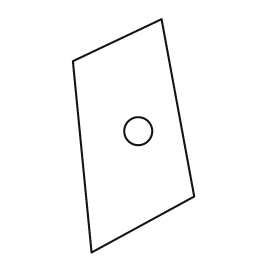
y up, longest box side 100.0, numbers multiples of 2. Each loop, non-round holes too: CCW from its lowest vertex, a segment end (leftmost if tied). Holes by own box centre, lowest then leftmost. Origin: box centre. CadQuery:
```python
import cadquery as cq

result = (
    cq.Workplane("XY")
    .moveTo(-18.0, -50.0)
    .lineTo(26.0, -26.0)
    .lineTo(12.0, 50.0)
    .lineTo(-26.0, 32.0)
    .close()
    .moveTo(2.0, 2.0)
    .circle(6.0)
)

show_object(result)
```